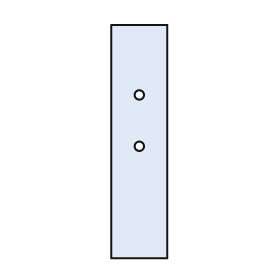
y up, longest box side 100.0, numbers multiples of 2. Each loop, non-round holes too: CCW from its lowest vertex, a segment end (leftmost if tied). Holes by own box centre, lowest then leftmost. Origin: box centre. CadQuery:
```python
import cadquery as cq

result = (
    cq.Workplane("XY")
    .moveTo(-12.0, -50.0)
    .lineTo(12.0, -50.0)
    .lineTo(12.0, 50.0)
    .lineTo(-12.0, 50.0)
    .close()
    .moveTo(0.0, -2.0)
    .circle(2.0)
    .moveTo(0.0, 20.0)
    .circle(2.0)
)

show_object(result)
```